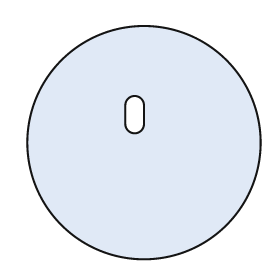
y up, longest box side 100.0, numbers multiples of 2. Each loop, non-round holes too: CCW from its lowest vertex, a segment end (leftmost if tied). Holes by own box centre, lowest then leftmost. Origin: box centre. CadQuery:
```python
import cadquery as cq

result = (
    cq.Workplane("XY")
    .moveTo(0.0, 0.0)
    .circle(50.0)
    .moveTo(-8.0, 8.0)
    .threePointArc((-4.0, 4.0), (0.0, 8.0))
    .lineTo(0.0, 16.0)
    .threePointArc((-4.0, 20.0), (-8.0, 16.0))
    .close()
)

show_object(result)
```